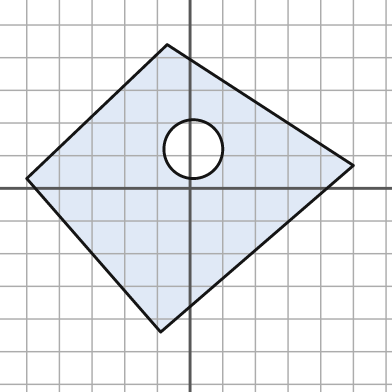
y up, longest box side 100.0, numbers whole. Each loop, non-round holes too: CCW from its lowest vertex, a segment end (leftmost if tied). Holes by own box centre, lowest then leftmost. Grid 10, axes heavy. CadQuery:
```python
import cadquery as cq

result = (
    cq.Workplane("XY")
    .moveTo(-9.0, -44.0)
    .lineTo(50.0, 7.0)
    .lineTo(-7.0, 44.0)
    .lineTo(-50.0, 3.0)
    .close()
    .moveTo(1.0, 12.0)
    .circle(9.0)
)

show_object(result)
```